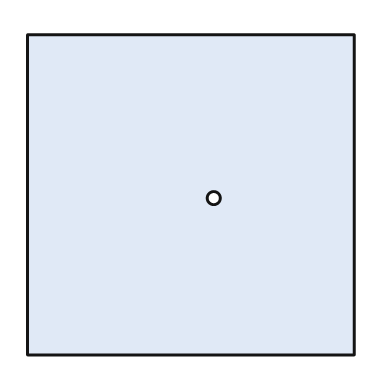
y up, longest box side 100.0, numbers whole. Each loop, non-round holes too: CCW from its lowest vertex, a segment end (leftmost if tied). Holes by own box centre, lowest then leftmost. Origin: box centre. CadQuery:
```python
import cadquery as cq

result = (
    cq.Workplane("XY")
    .moveTo(-50.0, -49.0)
    .lineTo(50.0, -49.0)
    .lineTo(50.0, 49.0)
    .lineTo(-50.0, 49.0)
    .close()
    .moveTo(7.0, -1.0)
    .circle(2.0)
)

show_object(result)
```